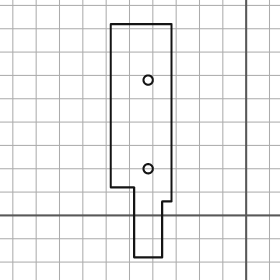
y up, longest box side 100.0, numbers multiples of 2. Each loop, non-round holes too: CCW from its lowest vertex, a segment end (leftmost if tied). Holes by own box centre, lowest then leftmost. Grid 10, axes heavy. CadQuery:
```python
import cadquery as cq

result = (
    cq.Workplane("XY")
    .moveTo(-48.0, -18.0)
    .lineTo(-36.0, -18.0)
    .lineTo(-36.0, 6.0)
    .lineTo(-32.0, 6.0)
    .lineTo(-32.0, 82.0)
    .lineTo(-58.0, 82.0)
    .lineTo(-58.0, 12.0)
    .lineTo(-48.0, 12.0)
    .close()
    .moveTo(-42.0, 20.0)
    .circle(2.0)
    .moveTo(-42.0, 58.0)
    .circle(2.0)
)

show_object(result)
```